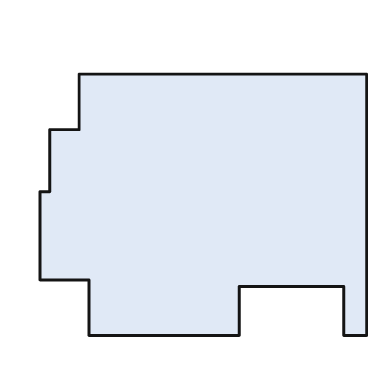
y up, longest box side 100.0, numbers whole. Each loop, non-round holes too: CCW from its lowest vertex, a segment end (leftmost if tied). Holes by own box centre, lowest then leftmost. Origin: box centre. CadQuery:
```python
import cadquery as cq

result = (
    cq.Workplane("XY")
    .moveTo(-35.0, -40.0)
    .lineTo(11.0, -40.0)
    .lineTo(11.0, -25.0)
    .lineTo(43.0, -25.0)
    .lineTo(43.0, -40.0)
    .lineTo(50.0, -40.0)
    .lineTo(50.0, 40.0)
    .lineTo(-38.0, 40.0)
    .lineTo(-38.0, 23.0)
    .lineTo(-47.0, 23.0)
    .lineTo(-47.0, 4.0)
    .lineTo(-50.0, 4.0)
    .lineTo(-50.0, -23.0)
    .lineTo(-35.0, -23.0)
    .close()
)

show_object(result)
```